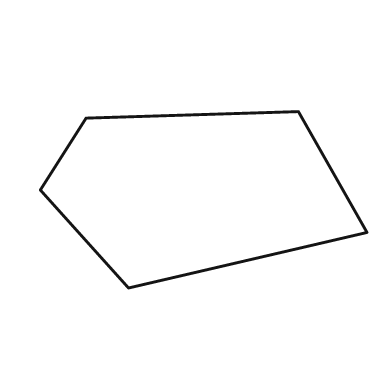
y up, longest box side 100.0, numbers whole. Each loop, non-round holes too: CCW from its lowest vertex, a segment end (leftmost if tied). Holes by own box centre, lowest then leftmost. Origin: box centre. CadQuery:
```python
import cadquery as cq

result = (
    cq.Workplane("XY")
    .moveTo(-23.0, -27.0)
    .lineTo(50.0, -10.0)
    .lineTo(29.0, 27.0)
    .lineTo(-36.0, 25.0)
    .lineTo(-50.0, 3.0)
    .close()
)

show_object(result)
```